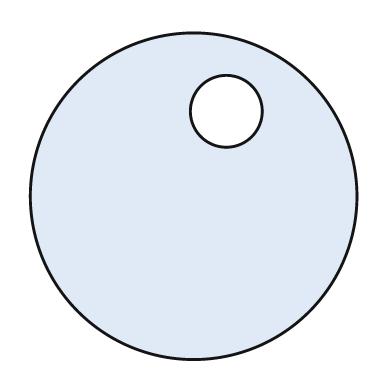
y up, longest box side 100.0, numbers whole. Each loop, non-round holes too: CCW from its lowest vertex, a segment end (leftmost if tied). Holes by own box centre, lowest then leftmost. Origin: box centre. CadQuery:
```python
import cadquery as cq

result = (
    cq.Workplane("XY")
    .moveTo(0.0, 0.0)
    .circle(50.0)
    .moveTo(10.0, 26.0)
    .circle(11.0)
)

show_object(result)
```